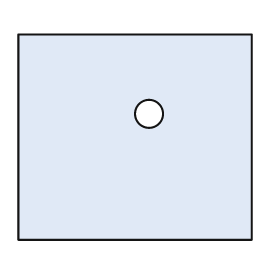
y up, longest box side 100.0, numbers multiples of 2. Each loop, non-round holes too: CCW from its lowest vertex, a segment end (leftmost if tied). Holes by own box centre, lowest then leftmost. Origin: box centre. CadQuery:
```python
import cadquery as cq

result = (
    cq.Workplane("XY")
    .moveTo(-50.0, -44.0)
    .lineTo(50.0, -44.0)
    .lineTo(50.0, 44.0)
    .lineTo(-50.0, 44.0)
    .close()
    .moveTo(6.0, 10.0)
    .circle(6.0)
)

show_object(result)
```